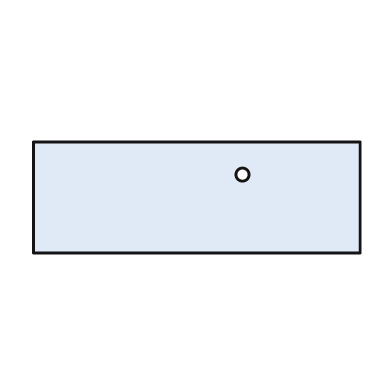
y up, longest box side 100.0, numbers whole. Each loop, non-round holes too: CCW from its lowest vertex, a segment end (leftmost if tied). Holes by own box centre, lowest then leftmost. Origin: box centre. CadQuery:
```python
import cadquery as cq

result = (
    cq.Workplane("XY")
    .moveTo(-50.0, -17.0)
    .lineTo(50.0, -17.0)
    .lineTo(50.0, 17.0)
    .lineTo(-50.0, 17.0)
    .close()
    .moveTo(14.0, 7.0)
    .circle(2.0)
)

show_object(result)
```